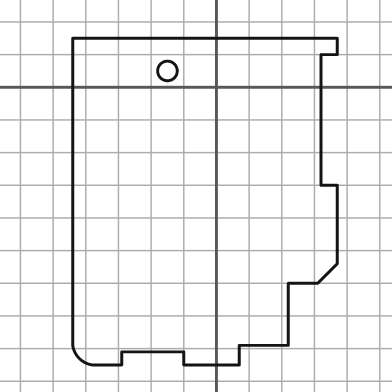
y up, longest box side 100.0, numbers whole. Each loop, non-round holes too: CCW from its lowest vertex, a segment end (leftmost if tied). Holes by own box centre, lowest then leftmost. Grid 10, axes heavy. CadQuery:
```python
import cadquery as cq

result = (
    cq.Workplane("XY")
    .moveTo(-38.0, -85.0)
    .lineTo(-29.0, -85.0)
    .lineTo(-29.0, -81.0)
    .lineTo(-10.0, -81.0)
    .lineTo(-10.0, -85.0)
    .lineTo(7.0, -85.0)
    .lineTo(7.0, -79.0)
    .lineTo(22.0, -79.0)
    .lineTo(22.0, -60.0)
    .lineTo(31.0, -60.0)
    .lineTo(37.0, -54.0)
    .lineTo(37.0, -30.0)
    .lineTo(32.0, -30.0)
    .lineTo(32.0, 10.0)
    .lineTo(37.0, 10.0)
    .lineTo(37.0, 15.0)
    .lineTo(-44.0, 15.0)
    .lineTo(-44.0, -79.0)
    .threePointArc((-42.0, -83.0), (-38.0, -85.0))
    .close()
    .moveTo(-15.0, 5.0)
    .circle(3.0)
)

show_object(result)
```